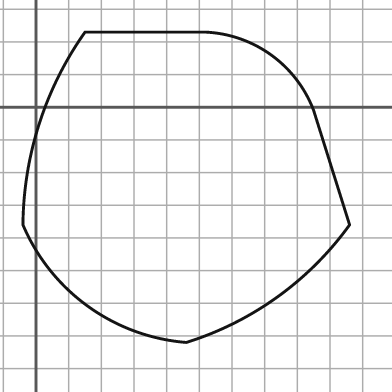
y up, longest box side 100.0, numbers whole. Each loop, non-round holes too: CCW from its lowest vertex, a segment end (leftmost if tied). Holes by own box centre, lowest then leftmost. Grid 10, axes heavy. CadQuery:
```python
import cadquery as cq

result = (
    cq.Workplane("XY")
    .moveTo(46.0, -72.0)
    .threePointArc((74.0, -58.0), (96.0, -36.0))
    .lineTo(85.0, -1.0)
    .threePointArc((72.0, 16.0), (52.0, 23.0))
    .lineTo(15.0, 23.0)
    .threePointArc((1.0, -5.0), (-4.0, -36.0))
    .threePointArc((16.0, -61.0), (46.0, -72.0))
    .close()
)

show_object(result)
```